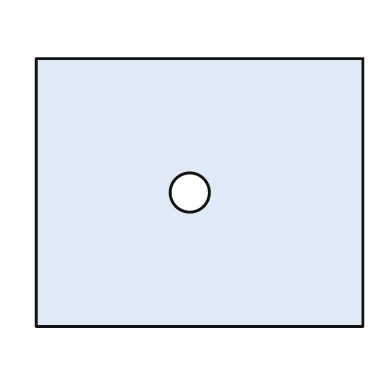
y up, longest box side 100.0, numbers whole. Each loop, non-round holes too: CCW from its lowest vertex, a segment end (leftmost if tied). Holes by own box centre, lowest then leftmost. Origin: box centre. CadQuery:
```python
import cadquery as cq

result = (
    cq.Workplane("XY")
    .moveTo(-50.0, -41.0)
    .lineTo(50.0, -41.0)
    .lineTo(50.0, 41.0)
    .lineTo(-50.0, 41.0)
    .close()
    .moveTo(-3.0, 0.0)
    .circle(6.0)
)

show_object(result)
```